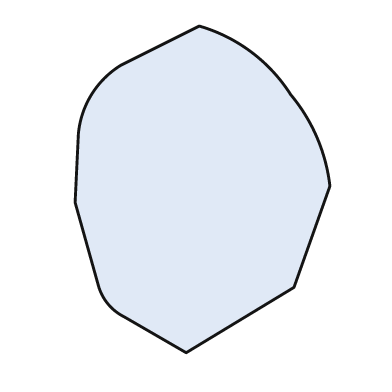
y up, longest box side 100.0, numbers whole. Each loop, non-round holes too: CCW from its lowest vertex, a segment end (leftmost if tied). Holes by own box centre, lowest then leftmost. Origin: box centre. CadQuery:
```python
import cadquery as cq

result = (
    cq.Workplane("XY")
    .moveTo(-5.0, -50.0)
    .lineTo(28.0, -30.0)
    .lineTo(39.0, 1.0)
    .threePointArc((35.0, 16.0), (27.0, 29.0))
    .threePointArc((15.0, 42.0), (-1.0, 50.0))
    .lineTo(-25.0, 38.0)
    .threePointArc((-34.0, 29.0), (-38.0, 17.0))
    .lineTo(-39.0, -4.0)
    .lineTo(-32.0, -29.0)
    .threePointArc((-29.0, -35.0), (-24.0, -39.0))
    .close()
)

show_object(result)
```